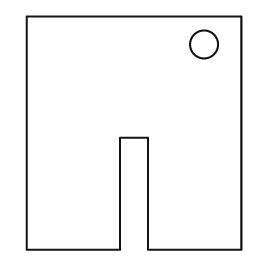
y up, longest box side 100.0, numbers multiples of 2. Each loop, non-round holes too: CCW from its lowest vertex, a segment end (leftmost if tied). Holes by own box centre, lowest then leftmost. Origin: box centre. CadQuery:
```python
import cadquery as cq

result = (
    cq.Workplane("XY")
    .moveTo(-46.0, -50.0)
    .lineTo(-6.0, -50.0)
    .lineTo(-6.0, -2.0)
    .lineTo(6.0, -2.0)
    .lineTo(6.0, -50.0)
    .lineTo(46.0, -50.0)
    .lineTo(46.0, 50.0)
    .lineTo(-46.0, 50.0)
    .close()
    .moveTo(30.0, 38.0)
    .circle(6.0)
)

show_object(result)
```